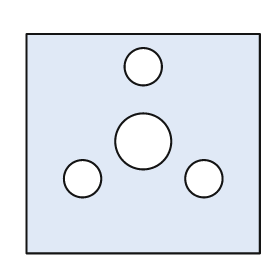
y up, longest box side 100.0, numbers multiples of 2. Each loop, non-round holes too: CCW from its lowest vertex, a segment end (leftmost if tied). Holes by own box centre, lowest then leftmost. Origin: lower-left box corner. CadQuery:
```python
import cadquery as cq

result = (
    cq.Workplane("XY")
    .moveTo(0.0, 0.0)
    .lineTo(100.0, 0.0)
    .lineTo(100.0, 94.0)
    .lineTo(0.0, 94.0)
    .close()
    .moveTo(24.0, 32.0)
    .circle(8.0)
    .moveTo(76.0, 32.0)
    .circle(8.0)
    .moveTo(50.0, 48.0)
    .circle(12.0)
    .moveTo(50.0, 80.0)
    .circle(8.0)
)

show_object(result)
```